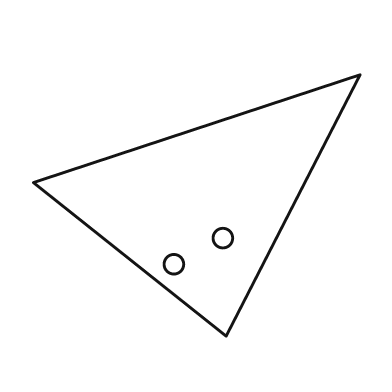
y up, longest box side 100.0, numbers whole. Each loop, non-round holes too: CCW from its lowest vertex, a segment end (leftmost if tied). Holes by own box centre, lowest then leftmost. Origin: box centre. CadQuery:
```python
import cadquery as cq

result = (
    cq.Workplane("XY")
    .moveTo(9.0, -40.0)
    .lineTo(50.0, 40.0)
    .lineTo(-50.0, 7.0)
    .close()
    .moveTo(-7.0, -18.0)
    .circle(3.0)
    .moveTo(8.0, -10.0)
    .circle(3.0)
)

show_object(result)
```